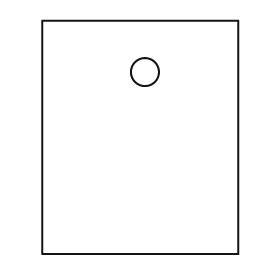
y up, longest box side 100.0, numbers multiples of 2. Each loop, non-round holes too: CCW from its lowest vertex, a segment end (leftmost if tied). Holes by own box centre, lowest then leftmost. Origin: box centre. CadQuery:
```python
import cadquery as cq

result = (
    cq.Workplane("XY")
    .moveTo(-42.0, -50.0)
    .lineTo(42.0, -50.0)
    .lineTo(42.0, 50.0)
    .lineTo(-42.0, 50.0)
    .close()
    .moveTo(2.0, 28.0)
    .circle(6.0)
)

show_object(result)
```